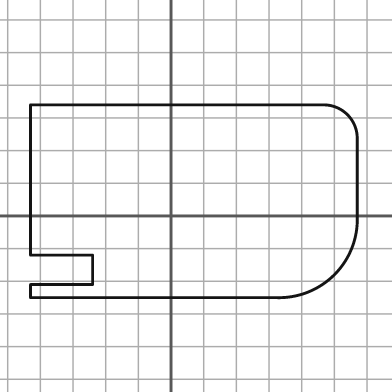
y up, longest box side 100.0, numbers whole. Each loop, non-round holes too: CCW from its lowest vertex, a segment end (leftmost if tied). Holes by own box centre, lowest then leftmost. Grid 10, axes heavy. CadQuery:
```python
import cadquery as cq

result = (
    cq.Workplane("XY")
    .moveTo(-43.0, -25.0)
    .lineTo(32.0, -25.0)
    .threePointArc((50.0, -18.0), (57.0, 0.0))
    .lineTo(57.0, 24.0)
    .threePointArc((54.0, 31.0), (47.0, 34.0))
    .lineTo(-43.0, 34.0)
    .lineTo(-43.0, -12.0)
    .lineTo(-24.0, -12.0)
    .lineTo(-24.0, -21.0)
    .lineTo(-43.0, -21.0)
    .close()
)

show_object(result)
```